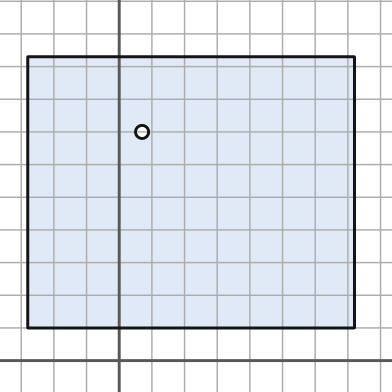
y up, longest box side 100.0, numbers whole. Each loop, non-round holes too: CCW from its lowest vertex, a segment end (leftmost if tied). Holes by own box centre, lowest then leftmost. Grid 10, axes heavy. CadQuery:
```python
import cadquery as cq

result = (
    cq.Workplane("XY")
    .moveTo(-28.0, 10.0)
    .lineTo(72.0, 10.0)
    .lineTo(72.0, 93.0)
    .lineTo(-28.0, 93.0)
    .close()
    .moveTo(7.0, 70.0)
    .circle(2.0)
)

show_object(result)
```